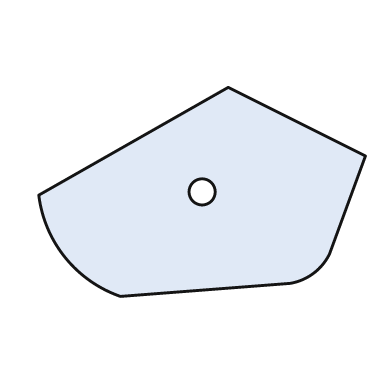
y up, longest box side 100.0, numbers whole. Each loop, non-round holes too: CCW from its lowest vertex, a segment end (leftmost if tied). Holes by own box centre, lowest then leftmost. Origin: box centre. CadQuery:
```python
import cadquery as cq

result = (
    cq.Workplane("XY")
    .moveTo(-25.0, -32.0)
    .lineTo(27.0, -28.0)
    .threePointArc((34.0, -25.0), (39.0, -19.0))
    .lineTo(50.0, 11.0)
    .lineTo(8.0, 32.0)
    .lineTo(-50.0, -1.0)
    .threePointArc((-42.0, -20.0), (-25.0, -32.0))
    .close()
    .moveTo(0.0, 0.0)
    .circle(4.0)
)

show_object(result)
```